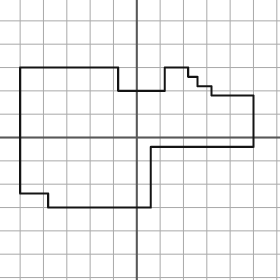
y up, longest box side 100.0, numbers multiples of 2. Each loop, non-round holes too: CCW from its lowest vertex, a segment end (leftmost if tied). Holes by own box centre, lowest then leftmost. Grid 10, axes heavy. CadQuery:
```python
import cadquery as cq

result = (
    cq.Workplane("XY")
    .moveTo(-38.0, -30.0)
    .lineTo(6.0, -30.0)
    .lineTo(6.0, -4.0)
    .lineTo(50.0, -4.0)
    .lineTo(50.0, 18.0)
    .lineTo(32.0, 18.0)
    .lineTo(32.0, 22.0)
    .lineTo(26.0, 22.0)
    .lineTo(26.0, 26.0)
    .lineTo(22.0, 26.0)
    .lineTo(22.0, 30.0)
    .lineTo(12.0, 30.0)
    .lineTo(12.0, 20.0)
    .lineTo(-8.0, 20.0)
    .lineTo(-8.0, 30.0)
    .lineTo(-50.0, 30.0)
    .lineTo(-50.0, -24.0)
    .lineTo(-38.0, -24.0)
    .close()
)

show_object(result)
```